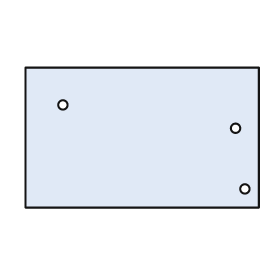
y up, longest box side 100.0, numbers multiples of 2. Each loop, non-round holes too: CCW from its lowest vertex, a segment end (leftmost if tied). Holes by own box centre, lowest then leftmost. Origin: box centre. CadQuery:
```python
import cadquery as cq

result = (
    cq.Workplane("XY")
    .moveTo(-50.0, -30.0)
    .lineTo(50.0, -30.0)
    .lineTo(50.0, 30.0)
    .lineTo(-50.0, 30.0)
    .close()
    .moveTo(44.0, -22.0)
    .circle(2.0)
    .moveTo(40.0, 4.0)
    .circle(2.0)
    .moveTo(-34.0, 14.0)
    .circle(2.0)
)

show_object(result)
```